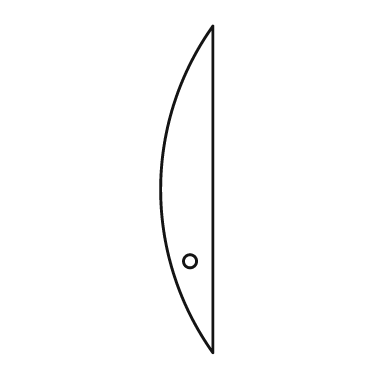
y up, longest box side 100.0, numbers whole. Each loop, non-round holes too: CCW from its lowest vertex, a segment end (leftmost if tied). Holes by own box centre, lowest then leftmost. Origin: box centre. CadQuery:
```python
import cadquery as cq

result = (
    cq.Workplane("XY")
    .moveTo(8.0, -50.0)
    .lineTo(8.0, 50.0)
    .threePointArc((-8.0, 0.0), (8.0, -50.0))
    .close()
    .moveTo(1.0, -22.0)
    .circle(2.0)
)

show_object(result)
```